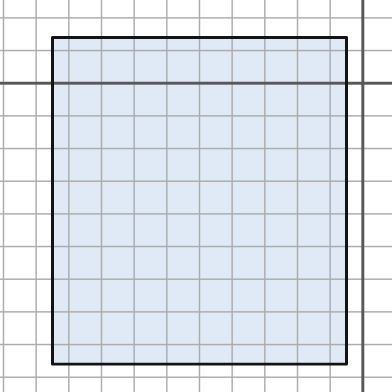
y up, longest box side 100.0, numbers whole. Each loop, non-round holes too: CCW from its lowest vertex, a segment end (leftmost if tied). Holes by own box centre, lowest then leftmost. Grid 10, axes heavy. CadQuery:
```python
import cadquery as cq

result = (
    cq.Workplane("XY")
    .moveTo(-95.0, -86.0)
    .lineTo(-5.0, -86.0)
    .lineTo(-5.0, 14.0)
    .lineTo(-95.0, 14.0)
    .close()
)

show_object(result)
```